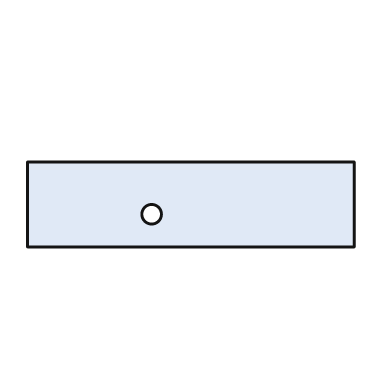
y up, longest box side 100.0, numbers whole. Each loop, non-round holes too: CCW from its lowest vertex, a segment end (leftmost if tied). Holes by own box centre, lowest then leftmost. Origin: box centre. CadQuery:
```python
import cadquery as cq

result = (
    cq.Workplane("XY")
    .moveTo(-50.0, -13.0)
    .lineTo(50.0, -13.0)
    .lineTo(50.0, 13.0)
    .lineTo(-50.0, 13.0)
    .close()
    .moveTo(-12.0, -3.0)
    .circle(3.0)
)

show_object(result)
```